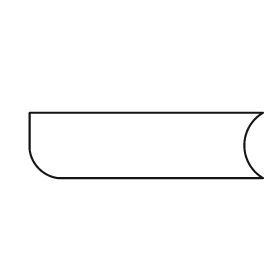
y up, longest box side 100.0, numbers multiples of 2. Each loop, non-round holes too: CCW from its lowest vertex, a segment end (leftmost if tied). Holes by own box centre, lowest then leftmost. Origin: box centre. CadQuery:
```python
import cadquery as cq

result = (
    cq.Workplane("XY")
    .moveTo(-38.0, -14.0)
    .lineTo(50.0, -14.0)
    .threePointArc((42.0, 0.0), (50.0, 14.0))
    .lineTo(-50.0, 14.0)
    .lineTo(-50.0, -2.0)
    .threePointArc((-46.0, -10.0), (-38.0, -14.0))
    .close()
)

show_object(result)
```